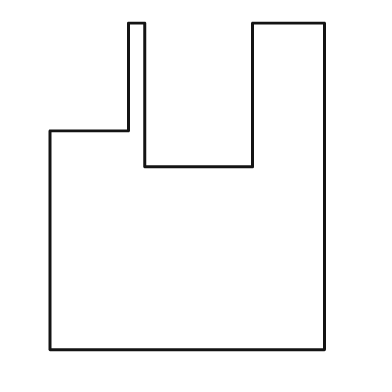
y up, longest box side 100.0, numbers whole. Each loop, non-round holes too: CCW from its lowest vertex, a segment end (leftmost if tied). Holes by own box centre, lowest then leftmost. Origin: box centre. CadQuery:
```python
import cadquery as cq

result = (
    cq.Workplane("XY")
    .moveTo(-42.0, -50.0)
    .lineTo(42.0, -50.0)
    .lineTo(42.0, 50.0)
    .lineTo(20.0, 50.0)
    .lineTo(20.0, 6.0)
    .lineTo(-13.0, 6.0)
    .lineTo(-13.0, 50.0)
    .lineTo(-18.0, 50.0)
    .lineTo(-18.0, 17.0)
    .lineTo(-42.0, 17.0)
    .close()
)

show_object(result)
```